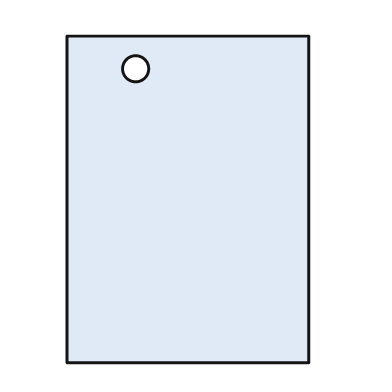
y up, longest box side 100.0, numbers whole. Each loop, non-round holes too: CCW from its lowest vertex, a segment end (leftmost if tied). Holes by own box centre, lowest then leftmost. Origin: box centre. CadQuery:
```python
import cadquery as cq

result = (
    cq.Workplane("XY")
    .moveTo(-37.0, -50.0)
    .lineTo(37.0, -50.0)
    .lineTo(37.0, 50.0)
    .lineTo(-37.0, 50.0)
    .close()
    .moveTo(-16.0, 40.0)
    .circle(4.0)
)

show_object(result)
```